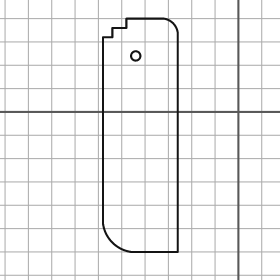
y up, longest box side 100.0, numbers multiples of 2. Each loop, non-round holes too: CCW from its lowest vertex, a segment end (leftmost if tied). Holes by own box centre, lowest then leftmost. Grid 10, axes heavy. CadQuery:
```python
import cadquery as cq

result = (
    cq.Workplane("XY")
    .moveTo(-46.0, -60.0)
    .lineTo(-26.0, -60.0)
    .lineTo(-26.0, 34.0)
    .threePointArc((-28.0, 38.0), (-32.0, 40.0))
    .lineTo(-48.0, 40.0)
    .lineTo(-48.0, 36.0)
    .lineTo(-54.0, 36.0)
    .lineTo(-54.0, 32.0)
    .lineTo(-58.0, 32.0)
    .lineTo(-58.0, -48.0)
    .threePointArc((-54.0, -56.0), (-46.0, -60.0))
    .close()
    .moveTo(-44.0, 24.0)
    .circle(2.0)
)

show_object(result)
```